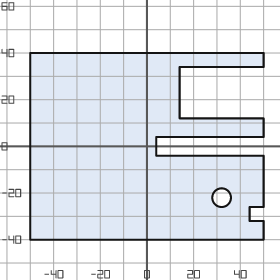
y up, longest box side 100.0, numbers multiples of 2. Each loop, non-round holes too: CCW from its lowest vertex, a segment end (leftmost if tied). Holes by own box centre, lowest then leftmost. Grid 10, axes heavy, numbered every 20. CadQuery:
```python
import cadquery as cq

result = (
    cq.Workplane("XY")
    .moveTo(-50.0, -40.0)
    .lineTo(50.0, -40.0)
    .lineTo(50.0, -32.0)
    .lineTo(44.0, -32.0)
    .lineTo(44.0, -26.0)
    .lineTo(50.0, -26.0)
    .lineTo(50.0, -4.0)
    .lineTo(4.0, -4.0)
    .lineTo(4.0, 4.0)
    .lineTo(50.0, 4.0)
    .lineTo(50.0, 12.0)
    .lineTo(14.0, 12.0)
    .lineTo(14.0, 34.0)
    .lineTo(50.0, 34.0)
    .lineTo(50.0, 40.0)
    .lineTo(-50.0, 40.0)
    .close()
    .moveTo(32.0, -22.0)
    .circle(4.0)
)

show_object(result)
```